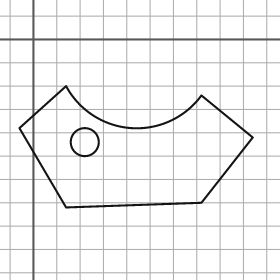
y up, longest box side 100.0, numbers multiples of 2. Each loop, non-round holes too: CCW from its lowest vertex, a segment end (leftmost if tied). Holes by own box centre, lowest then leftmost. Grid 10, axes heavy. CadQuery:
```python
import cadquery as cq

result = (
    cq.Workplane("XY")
    .moveTo(14.0, -72.0)
    .lineTo(72.0, -70.0)
    .lineTo(94.0, -42.0)
    .lineTo(72.0, -24.0)
    .threePointArc((42.0, -38.0), (14.0, -20.0))
    .lineTo(-6.0, -38.0)
    .close()
    .moveTo(22.0, -44.0)
    .circle(6.0)
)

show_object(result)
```